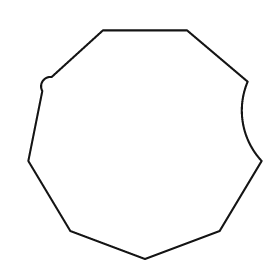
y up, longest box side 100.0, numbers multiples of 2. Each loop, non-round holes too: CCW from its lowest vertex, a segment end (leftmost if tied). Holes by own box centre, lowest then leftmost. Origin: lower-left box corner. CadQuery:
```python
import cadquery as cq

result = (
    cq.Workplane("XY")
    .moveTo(50.0, 0.0)
    .lineTo(82.0, 12.0)
    .lineTo(100.0, 42.0)
    .threePointArc((92.0, 58.0), (94.0, 76.0))
    .lineTo(68.0, 98.0)
    .lineTo(32.0, 98.0)
    .lineTo(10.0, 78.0)
    .threePointArc((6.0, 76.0), (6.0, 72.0))
    .lineTo(0.0, 42.0)
    .lineTo(18.0, 12.0)
    .close()
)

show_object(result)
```